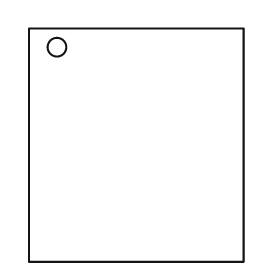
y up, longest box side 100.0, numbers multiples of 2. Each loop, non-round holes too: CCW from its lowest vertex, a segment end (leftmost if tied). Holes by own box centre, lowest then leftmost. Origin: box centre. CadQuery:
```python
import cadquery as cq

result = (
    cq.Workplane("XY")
    .moveTo(-46.0, -50.0)
    .lineTo(46.0, -50.0)
    .lineTo(46.0, 50.0)
    .lineTo(-46.0, 50.0)
    .close()
    .moveTo(-34.0, 42.0)
    .circle(4.0)
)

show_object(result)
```